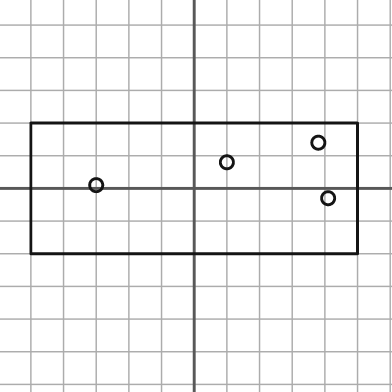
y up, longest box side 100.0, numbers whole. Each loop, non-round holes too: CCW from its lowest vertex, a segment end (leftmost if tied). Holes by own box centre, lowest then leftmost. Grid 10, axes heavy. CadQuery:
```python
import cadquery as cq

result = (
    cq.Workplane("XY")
    .moveTo(-50.0, -20.0)
    .lineTo(50.0, -20.0)
    .lineTo(50.0, 20.0)
    .lineTo(-50.0, 20.0)
    .close()
    .moveTo(41.0, -3.0)
    .circle(2.0)
    .moveTo(-30.0, 1.0)
    .circle(2.0)
    .moveTo(10.0, 8.0)
    .circle(2.0)
    .moveTo(38.0, 14.0)
    .circle(2.0)
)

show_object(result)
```